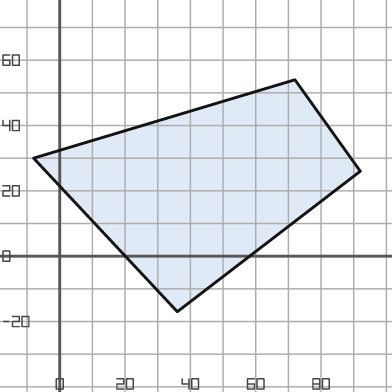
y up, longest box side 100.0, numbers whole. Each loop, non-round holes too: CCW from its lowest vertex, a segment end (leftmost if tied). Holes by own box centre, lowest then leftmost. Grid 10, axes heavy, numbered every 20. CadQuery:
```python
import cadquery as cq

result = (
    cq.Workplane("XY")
    .moveTo(36.0, -17.0)
    .lineTo(92.0, 26.0)
    .lineTo(72.0, 54.0)
    .lineTo(-8.0, 30.0)
    .close()
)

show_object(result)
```